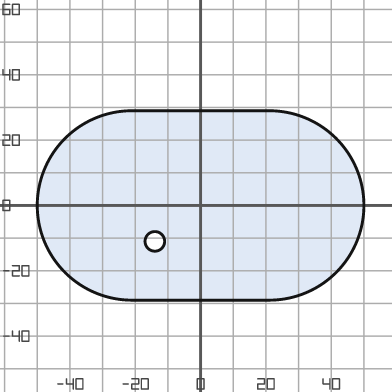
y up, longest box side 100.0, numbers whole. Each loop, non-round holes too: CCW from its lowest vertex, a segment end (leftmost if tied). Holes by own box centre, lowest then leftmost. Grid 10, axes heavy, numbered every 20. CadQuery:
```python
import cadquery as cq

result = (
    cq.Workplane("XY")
    .moveTo(-21.0, -29.0)
    .lineTo(21.0, -29.0)
    .threePointArc((50.0, 0.0), (21.0, 29.0))
    .lineTo(-21.0, 29.0)
    .threePointArc((-50.0, 0.0), (-21.0, -29.0))
    .close()
    .moveTo(-14.0, -11.0)
    .circle(3.0)
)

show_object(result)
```